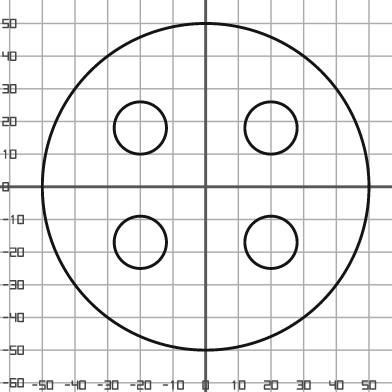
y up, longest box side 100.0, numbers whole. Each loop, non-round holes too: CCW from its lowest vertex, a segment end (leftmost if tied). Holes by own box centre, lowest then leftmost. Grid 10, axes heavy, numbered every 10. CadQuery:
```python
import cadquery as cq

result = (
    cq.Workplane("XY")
    .moveTo(0.0, 0.0)
    .circle(50.0)
    .moveTo(-20.0, -17.0)
    .circle(8.0)
    .moveTo(20.0, -17.0)
    .circle(8.0)
    .moveTo(-20.0, 18.0)
    .circle(8.0)
    .moveTo(20.0, 18.0)
    .circle(8.0)
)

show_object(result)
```